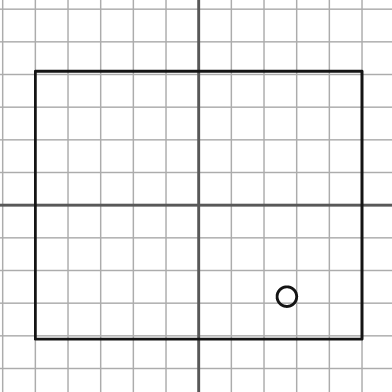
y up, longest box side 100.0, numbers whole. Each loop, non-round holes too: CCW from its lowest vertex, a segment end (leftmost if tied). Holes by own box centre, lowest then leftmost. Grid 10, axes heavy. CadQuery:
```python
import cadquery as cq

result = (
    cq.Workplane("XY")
    .moveTo(-50.0, -41.0)
    .lineTo(50.0, -41.0)
    .lineTo(50.0, 41.0)
    .lineTo(-50.0, 41.0)
    .close()
    .moveTo(27.0, -28.0)
    .circle(3.0)
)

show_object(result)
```